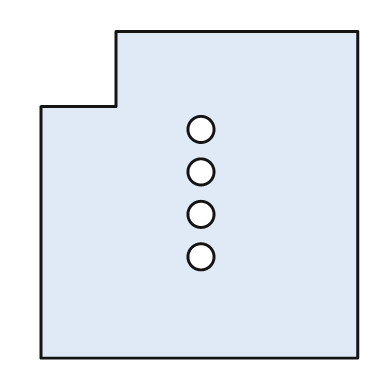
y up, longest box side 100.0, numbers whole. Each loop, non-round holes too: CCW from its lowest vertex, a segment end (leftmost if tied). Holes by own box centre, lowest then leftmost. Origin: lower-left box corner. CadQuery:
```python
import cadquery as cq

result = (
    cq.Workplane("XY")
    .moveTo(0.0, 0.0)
    .lineTo(97.0, 0.0)
    .lineTo(97.0, 100.0)
    .lineTo(23.0, 100.0)
    .lineTo(23.0, 77.0)
    .lineTo(0.0, 77.0)
    .close()
    .moveTo(49.0, 31.0)
    .circle(4.0)
    .moveTo(49.0, 44.0)
    .circle(4.0)
    .moveTo(49.0, 57.0)
    .circle(4.0)
    .moveTo(49.0, 70.0)
    .circle(4.0)
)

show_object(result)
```